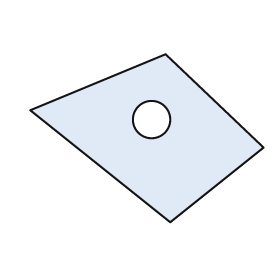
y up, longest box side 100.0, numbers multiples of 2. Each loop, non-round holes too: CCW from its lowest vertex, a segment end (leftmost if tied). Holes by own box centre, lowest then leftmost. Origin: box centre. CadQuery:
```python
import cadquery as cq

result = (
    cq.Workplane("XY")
    .moveTo(10.0, -36.0)
    .lineTo(50.0, -4.0)
    .lineTo(8.0, 36.0)
    .lineTo(-50.0, 12.0)
    .close()
    .moveTo(2.0, 8.0)
    .circle(8.0)
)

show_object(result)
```